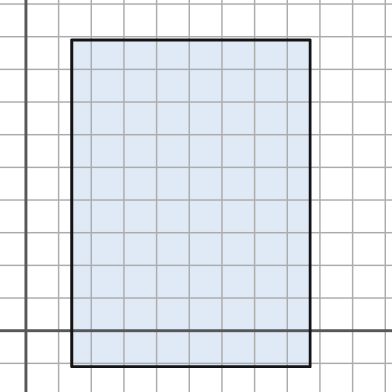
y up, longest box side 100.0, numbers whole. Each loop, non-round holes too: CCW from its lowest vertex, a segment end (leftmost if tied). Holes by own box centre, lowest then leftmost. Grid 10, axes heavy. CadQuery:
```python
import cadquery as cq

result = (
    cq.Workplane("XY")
    .moveTo(14.0, -11.0)
    .lineTo(87.0, -11.0)
    .lineTo(87.0, 89.0)
    .lineTo(14.0, 89.0)
    .close()
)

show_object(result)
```